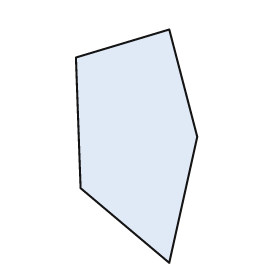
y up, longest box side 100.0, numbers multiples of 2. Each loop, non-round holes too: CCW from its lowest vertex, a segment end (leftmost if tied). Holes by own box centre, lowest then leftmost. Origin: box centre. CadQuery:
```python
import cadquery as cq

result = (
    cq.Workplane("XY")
    .moveTo(14.0, -50.0)
    .lineTo(26.0, 4.0)
    .lineTo(14.0, 50.0)
    .lineTo(-26.0, 38.0)
    .lineTo(-24.0, -18.0)
    .close()
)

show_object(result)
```